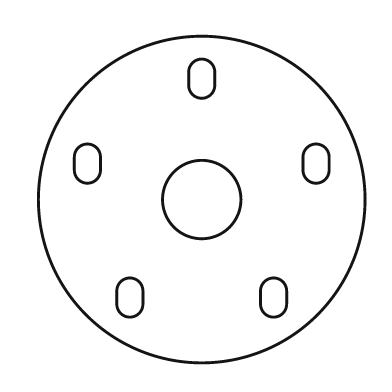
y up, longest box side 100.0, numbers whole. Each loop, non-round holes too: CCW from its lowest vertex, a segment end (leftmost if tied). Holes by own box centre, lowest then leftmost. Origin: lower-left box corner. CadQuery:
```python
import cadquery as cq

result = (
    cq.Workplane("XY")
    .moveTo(50.0, 50.0)
    .circle(50.0)
    .moveTo(24.0, 18.0)
    .threePointArc((28.0, 14.0), (32.0, 18.0))
    .lineTo(32.0, 22.0)
    .threePointArc((28.0, 26.0), (24.0, 22.0))
    .close()
    .moveTo(68.0, 18.0)
    .threePointArc((72.0, 14.0), (76.0, 18.0))
    .lineTo(76.0, 22.0)
    .threePointArc((72.0, 26.0), (68.0, 22.0))
    .close()
    .moveTo(50.0, 50.0)
    .circle(12.0)
    .moveTo(11.0, 59.0)
    .threePointArc((15.0, 55.0), (19.0, 59.0))
    .lineTo(19.0, 63.0)
    .threePointArc((15.0, 67.0), (11.0, 63.0))
    .close()
    .moveTo(81.0, 59.0)
    .threePointArc((85.0, 55.0), (89.0, 59.0))
    .lineTo(89.0, 63.0)
    .threePointArc((85.0, 67.0), (81.0, 63.0))
    .close()
    .moveTo(46.0, 85.0)
    .threePointArc((50.0, 81.0), (54.0, 85.0))
    .lineTo(54.0, 89.0)
    .threePointArc((50.0, 93.0), (46.0, 89.0))
    .close()
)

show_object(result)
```